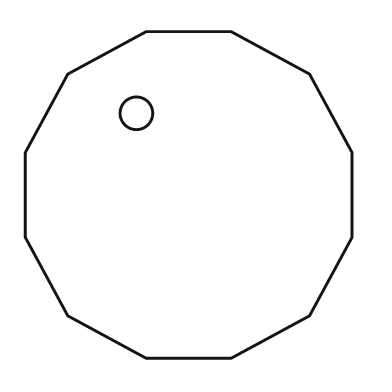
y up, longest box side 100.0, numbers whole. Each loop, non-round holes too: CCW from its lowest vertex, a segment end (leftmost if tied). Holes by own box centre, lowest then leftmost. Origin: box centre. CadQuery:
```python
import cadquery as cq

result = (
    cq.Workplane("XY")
    .moveTo(-13.0, -50.0)
    .lineTo(13.0, -50.0)
    .lineTo(37.0, -37.0)
    .lineTo(50.0, -13.0)
    .lineTo(50.0, 13.0)
    .lineTo(37.0, 37.0)
    .lineTo(13.0, 50.0)
    .lineTo(-13.0, 50.0)
    .lineTo(-37.0, 37.0)
    .lineTo(-50.0, 13.0)
    .lineTo(-50.0, -13.0)
    .lineTo(-37.0, -37.0)
    .close()
    .moveTo(-16.0, 25.0)
    .circle(5.0)
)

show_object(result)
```